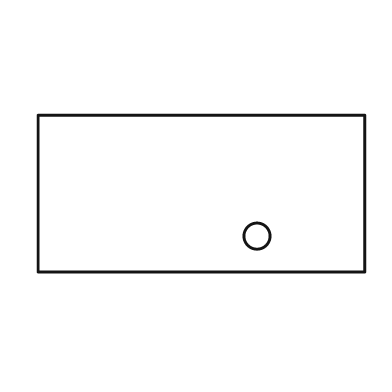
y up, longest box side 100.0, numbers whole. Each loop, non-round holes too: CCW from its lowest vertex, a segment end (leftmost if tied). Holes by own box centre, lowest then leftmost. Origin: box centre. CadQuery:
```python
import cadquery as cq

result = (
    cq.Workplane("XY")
    .moveTo(-50.0, -24.0)
    .lineTo(50.0, -24.0)
    .lineTo(50.0, 24.0)
    .lineTo(-50.0, 24.0)
    .close()
    .moveTo(17.0, -13.0)
    .circle(4.0)
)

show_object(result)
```